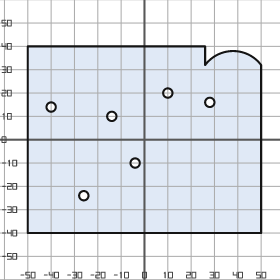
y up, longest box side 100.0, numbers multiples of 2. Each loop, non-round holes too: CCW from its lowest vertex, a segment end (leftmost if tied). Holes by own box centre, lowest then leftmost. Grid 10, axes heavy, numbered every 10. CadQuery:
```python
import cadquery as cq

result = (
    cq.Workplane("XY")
    .moveTo(-50.0, -40.0)
    .lineTo(50.0, -40.0)
    .lineTo(50.0, 32.0)
    .threePointArc((38.0, 38.0), (26.0, 32.0))
    .lineTo(26.0, 40.0)
    .lineTo(-50.0, 40.0)
    .close()
    .moveTo(-26.0, -24.0)
    .circle(2.0)
    .moveTo(-4.0, -10.0)
    .circle(2.0)
    .moveTo(-14.0, 10.0)
    .circle(2.0)
    .moveTo(-40.0, 14.0)
    .circle(2.0)
    .moveTo(28.0, 16.0)
    .circle(2.0)
    .moveTo(10.0, 20.0)
    .circle(2.0)
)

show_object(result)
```